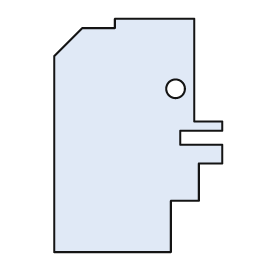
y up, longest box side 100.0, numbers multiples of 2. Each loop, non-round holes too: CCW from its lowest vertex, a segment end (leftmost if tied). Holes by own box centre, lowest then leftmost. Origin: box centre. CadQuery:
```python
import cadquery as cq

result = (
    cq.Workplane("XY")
    .moveTo(-36.0, -50.0)
    .lineTo(14.0, -50.0)
    .lineTo(14.0, -28.0)
    .lineTo(26.0, -28.0)
    .lineTo(26.0, -12.0)
    .lineTo(36.0, -12.0)
    .lineTo(36.0, -4.0)
    .lineTo(18.0, -4.0)
    .lineTo(18.0, 2.0)
    .lineTo(36.0, 2.0)
    .lineTo(36.0, 6.0)
    .lineTo(24.0, 6.0)
    .lineTo(24.0, 50.0)
    .lineTo(-10.0, 50.0)
    .lineTo(-10.0, 46.0)
    .lineTo(-24.0, 46.0)
    .lineTo(-36.0, 34.0)
    .close()
    .moveTo(16.0, 20.0)
    .circle(4.0)
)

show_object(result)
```